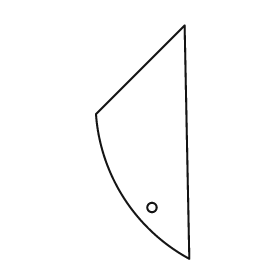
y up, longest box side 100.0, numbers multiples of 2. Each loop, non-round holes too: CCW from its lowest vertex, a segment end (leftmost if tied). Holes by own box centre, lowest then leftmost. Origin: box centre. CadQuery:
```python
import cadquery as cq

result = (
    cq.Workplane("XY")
    .moveTo(20.0, -50.0)
    .lineTo(18.0, 50.0)
    .lineTo(-20.0, 12.0)
    .threePointArc((-8.0, -24.0), (20.0, -50.0))
    .close()
    .moveTo(4.0, -28.0)
    .circle(2.0)
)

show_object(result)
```